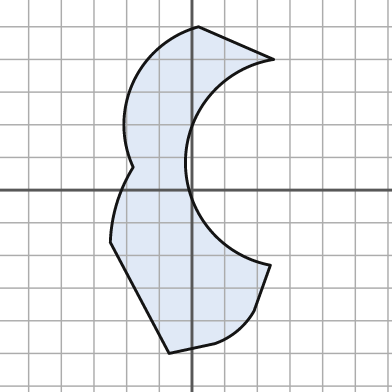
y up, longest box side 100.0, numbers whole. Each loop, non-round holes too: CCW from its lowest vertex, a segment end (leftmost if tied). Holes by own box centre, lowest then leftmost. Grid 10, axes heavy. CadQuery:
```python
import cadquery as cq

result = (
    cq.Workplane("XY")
    .moveTo(-7.0, -50.0)
    .lineTo(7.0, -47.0)
    .threePointArc((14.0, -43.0), (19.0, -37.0))
    .lineTo(24.0, -23.0)
    .threePointArc((-2.0, 9.0), (25.0, 40.0))
    .lineTo(2.0, 50.0)
    .threePointArc((-18.0, 33.0), (-18.0, 7.0))
    .threePointArc((-23.0, -4.0), (-25.0, -16.0))
    .close()
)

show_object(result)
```